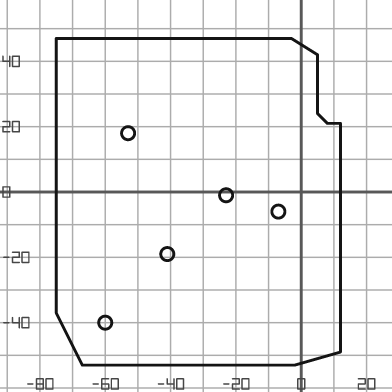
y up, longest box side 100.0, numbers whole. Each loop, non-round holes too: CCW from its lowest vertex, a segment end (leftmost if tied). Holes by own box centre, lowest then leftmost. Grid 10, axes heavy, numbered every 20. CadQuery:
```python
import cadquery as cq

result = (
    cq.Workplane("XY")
    .moveTo(-67.0, -53.0)
    .lineTo(-2.0, -53.0)
    .lineTo(12.0, -49.0)
    .lineTo(12.0, 21.0)
    .lineTo(8.0, 21.0)
    .lineTo(5.0, 24.0)
    .lineTo(5.0, 42.0)
    .lineTo(-3.0, 47.0)
    .lineTo(-75.0, 47.0)
    .lineTo(-75.0, -37.0)
    .close()
    .moveTo(-60.0, -40.0)
    .circle(2.0)
    .moveTo(-41.0, -19.0)
    .circle(2.0)
    .moveTo(-7.0, -6.0)
    .circle(2.0)
    .moveTo(-23.0, -1.0)
    .circle(2.0)
    .moveTo(-53.0, 18.0)
    .circle(2.0)
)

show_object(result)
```